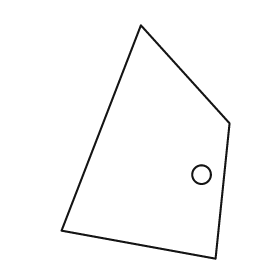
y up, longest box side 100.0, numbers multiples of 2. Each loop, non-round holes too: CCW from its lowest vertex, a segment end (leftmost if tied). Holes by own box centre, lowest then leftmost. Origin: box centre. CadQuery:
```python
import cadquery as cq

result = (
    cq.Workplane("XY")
    .moveTo(30.0, -50.0)
    .lineTo(36.0, 8.0)
    .lineTo(-2.0, 50.0)
    .lineTo(-36.0, -38.0)
    .close()
    .moveTo(24.0, -14.0)
    .circle(4.0)
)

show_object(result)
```